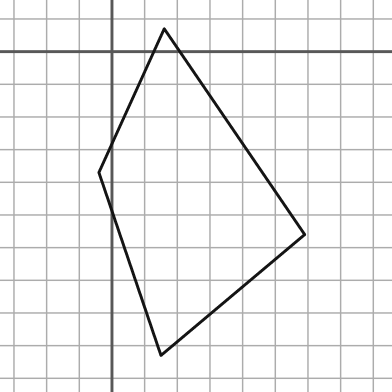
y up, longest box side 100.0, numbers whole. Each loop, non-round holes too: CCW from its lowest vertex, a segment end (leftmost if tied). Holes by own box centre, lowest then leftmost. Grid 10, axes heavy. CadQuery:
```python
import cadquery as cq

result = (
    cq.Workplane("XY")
    .moveTo(15.0, -93.0)
    .lineTo(59.0, -56.0)
    .lineTo(16.0, 7.0)
    .lineTo(-4.0, -37.0)
    .close()
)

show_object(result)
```